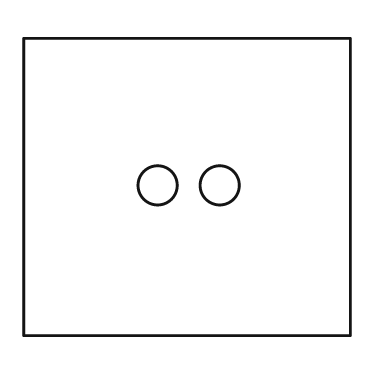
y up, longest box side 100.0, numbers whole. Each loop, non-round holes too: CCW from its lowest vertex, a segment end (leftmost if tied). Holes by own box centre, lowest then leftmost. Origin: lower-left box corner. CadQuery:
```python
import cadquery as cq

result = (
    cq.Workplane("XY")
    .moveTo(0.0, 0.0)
    .lineTo(100.0, 0.0)
    .lineTo(100.0, 91.0)
    .lineTo(0.0, 91.0)
    .close()
    .moveTo(41.0, 46.0)
    .circle(6.0)
    .moveTo(60.0, 46.0)
    .circle(6.0)
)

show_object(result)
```